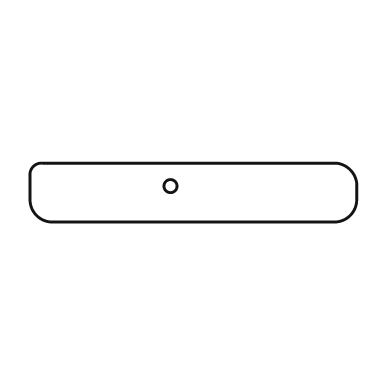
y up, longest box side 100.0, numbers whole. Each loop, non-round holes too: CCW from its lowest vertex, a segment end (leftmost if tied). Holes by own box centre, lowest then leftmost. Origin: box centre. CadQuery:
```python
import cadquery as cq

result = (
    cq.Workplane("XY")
    .moveTo(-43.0, -9.0)
    .lineTo(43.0, -9.0)
    .threePointArc((48.0, -7.0), (50.0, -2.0))
    .lineTo(50.0, 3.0)
    .threePointArc((48.0, 7.0), (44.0, 9.0))
    .lineTo(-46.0, 9.0)
    .threePointArc((-49.0, 8.0), (-50.0, 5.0))
    .lineTo(-50.0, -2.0)
    .threePointArc((-48.0, -7.0), (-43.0, -9.0))
    .close()
    .moveTo(-7.0, 2.0)
    .circle(2.0)
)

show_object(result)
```